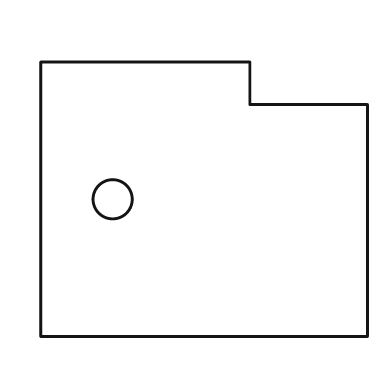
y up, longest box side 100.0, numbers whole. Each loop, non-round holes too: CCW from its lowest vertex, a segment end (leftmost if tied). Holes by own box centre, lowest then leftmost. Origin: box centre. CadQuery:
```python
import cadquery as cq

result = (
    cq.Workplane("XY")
    .moveTo(-50.0, -42.0)
    .lineTo(50.0, -42.0)
    .lineTo(50.0, 29.0)
    .lineTo(14.0, 29.0)
    .lineTo(14.0, 42.0)
    .lineTo(-50.0, 42.0)
    .close()
    .moveTo(-28.0, 0.0)
    .circle(6.0)
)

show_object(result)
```